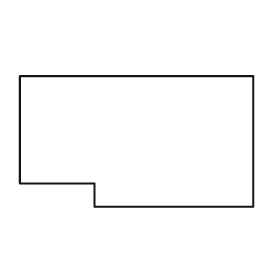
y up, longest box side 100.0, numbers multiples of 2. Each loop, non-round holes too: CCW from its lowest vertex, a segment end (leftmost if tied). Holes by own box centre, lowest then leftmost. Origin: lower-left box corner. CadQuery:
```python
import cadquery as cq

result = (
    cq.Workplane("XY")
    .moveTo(32.0, 0.0)
    .lineTo(100.0, 0.0)
    .lineTo(100.0, 56.0)
    .lineTo(0.0, 56.0)
    .lineTo(0.0, 10.0)
    .lineTo(32.0, 10.0)
    .close()
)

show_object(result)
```